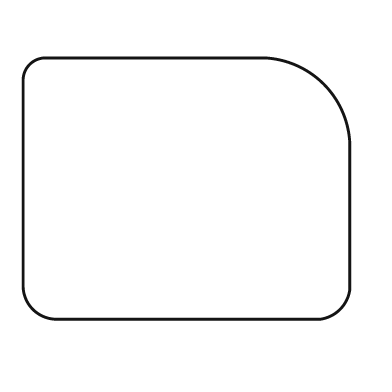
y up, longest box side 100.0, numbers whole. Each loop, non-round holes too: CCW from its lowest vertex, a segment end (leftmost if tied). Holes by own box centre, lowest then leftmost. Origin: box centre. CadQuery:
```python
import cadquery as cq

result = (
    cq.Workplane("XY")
    .moveTo(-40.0, -40.0)
    .lineTo(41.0, -40.0)
    .threePointArc((47.0, -37.0), (50.0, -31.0))
    .lineTo(50.0, 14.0)
    .threePointArc((42.0, 32.0), (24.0, 40.0))
    .lineTo(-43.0, 40.0)
    .threePointArc((-48.0, 38.0), (-50.0, 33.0))
    .lineTo(-50.0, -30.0)
    .threePointArc((-47.0, -37.0), (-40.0, -40.0))
    .close()
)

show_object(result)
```